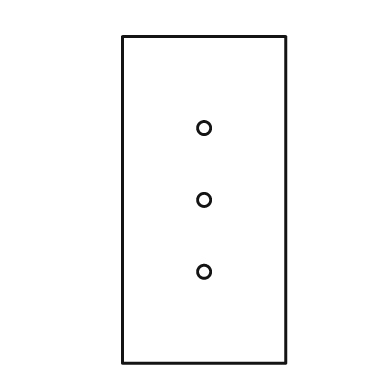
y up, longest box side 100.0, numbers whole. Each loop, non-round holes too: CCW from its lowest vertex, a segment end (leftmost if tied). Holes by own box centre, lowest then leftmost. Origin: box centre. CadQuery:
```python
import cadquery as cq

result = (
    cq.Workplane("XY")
    .moveTo(-25.0, -50.0)
    .lineTo(25.0, -50.0)
    .lineTo(25.0, 50.0)
    .lineTo(-25.0, 50.0)
    .close()
    .moveTo(0.0, -22.0)
    .circle(2.0)
    .moveTo(0.0, 0.0)
    .circle(2.0)
    .moveTo(0.0, 22.0)
    .circle(2.0)
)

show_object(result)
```